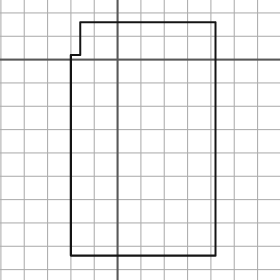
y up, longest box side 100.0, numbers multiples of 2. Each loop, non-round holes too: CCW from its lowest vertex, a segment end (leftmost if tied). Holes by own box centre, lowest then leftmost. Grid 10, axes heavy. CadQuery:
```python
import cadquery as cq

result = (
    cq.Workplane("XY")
    .moveTo(-20.0, -84.0)
    .lineTo(42.0, -84.0)
    .lineTo(42.0, 16.0)
    .lineTo(-16.0, 16.0)
    .lineTo(-16.0, 2.0)
    .lineTo(-20.0, 2.0)
    .close()
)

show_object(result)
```